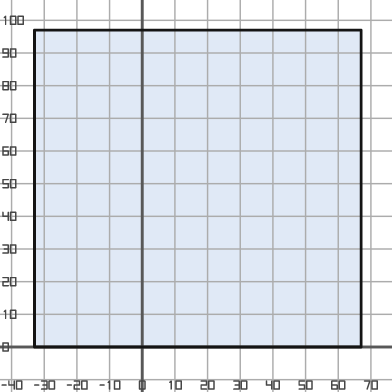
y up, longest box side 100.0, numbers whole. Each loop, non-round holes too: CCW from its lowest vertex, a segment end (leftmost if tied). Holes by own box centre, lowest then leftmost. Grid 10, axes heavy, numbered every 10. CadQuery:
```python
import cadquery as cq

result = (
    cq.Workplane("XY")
    .moveTo(-33.0, 0.0)
    .lineTo(67.0, 0.0)
    .lineTo(67.0, 97.0)
    .lineTo(-33.0, 97.0)
    .close()
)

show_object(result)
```